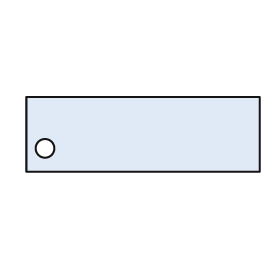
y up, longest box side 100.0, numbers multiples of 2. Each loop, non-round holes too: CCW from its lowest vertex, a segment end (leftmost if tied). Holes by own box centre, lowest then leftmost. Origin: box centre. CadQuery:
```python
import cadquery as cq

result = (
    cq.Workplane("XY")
    .moveTo(-50.0, -16.0)
    .lineTo(50.0, -16.0)
    .lineTo(50.0, 16.0)
    .lineTo(-50.0, 16.0)
    .close()
    .moveTo(-42.0, -6.0)
    .circle(4.0)
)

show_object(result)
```